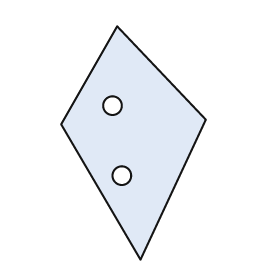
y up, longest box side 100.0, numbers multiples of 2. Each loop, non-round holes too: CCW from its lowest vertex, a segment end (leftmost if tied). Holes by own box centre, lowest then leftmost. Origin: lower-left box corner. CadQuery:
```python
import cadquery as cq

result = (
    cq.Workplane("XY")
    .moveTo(34.0, 0.0)
    .lineTo(62.0, 60.0)
    .lineTo(24.0, 100.0)
    .lineTo(0.0, 58.0)
    .close()
    .moveTo(26.0, 36.0)
    .circle(4.0)
    .moveTo(22.0, 66.0)
    .circle(4.0)
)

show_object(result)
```